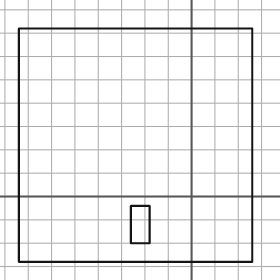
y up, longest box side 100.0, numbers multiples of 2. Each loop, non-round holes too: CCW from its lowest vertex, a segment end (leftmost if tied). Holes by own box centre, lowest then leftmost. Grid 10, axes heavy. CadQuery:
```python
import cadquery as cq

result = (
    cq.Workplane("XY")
    .moveTo(-74.0, -28.0)
    .lineTo(26.0, -28.0)
    .lineTo(26.0, 72.0)
    .lineTo(-74.0, 72.0)
    .close()
    .moveTo(-26.0, -20.0)
    .lineTo(-18.0, -20.0)
    .lineTo(-18.0, -4.0)
    .lineTo(-26.0, -4.0)
    .close()
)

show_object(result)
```